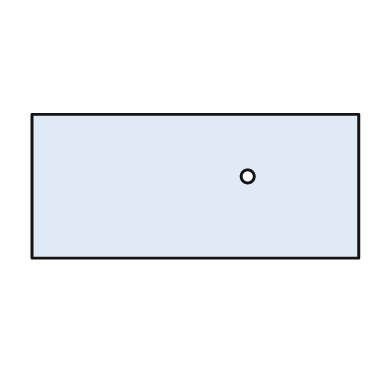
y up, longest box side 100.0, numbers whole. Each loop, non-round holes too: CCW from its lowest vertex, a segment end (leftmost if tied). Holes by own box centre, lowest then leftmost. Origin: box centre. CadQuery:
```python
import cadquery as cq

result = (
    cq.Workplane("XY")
    .moveTo(-50.0, -22.0)
    .lineTo(50.0, -22.0)
    .lineTo(50.0, 22.0)
    .lineTo(-50.0, 22.0)
    .close()
    .moveTo(16.0, 3.0)
    .circle(2.0)
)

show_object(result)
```